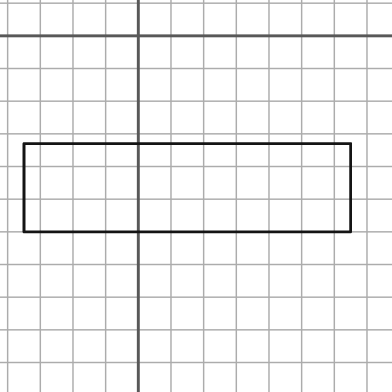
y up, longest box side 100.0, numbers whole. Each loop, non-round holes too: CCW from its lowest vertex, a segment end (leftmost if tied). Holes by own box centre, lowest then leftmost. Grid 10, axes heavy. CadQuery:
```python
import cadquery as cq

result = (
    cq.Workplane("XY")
    .moveTo(-35.0, -60.0)
    .lineTo(65.0, -60.0)
    .lineTo(65.0, -33.0)
    .lineTo(-35.0, -33.0)
    .close()
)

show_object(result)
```